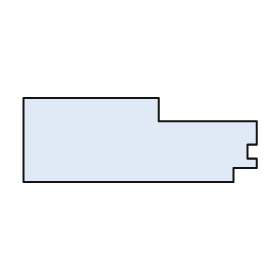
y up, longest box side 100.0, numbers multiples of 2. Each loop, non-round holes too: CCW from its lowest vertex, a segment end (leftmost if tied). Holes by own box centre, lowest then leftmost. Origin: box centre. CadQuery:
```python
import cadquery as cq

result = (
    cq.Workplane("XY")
    .moveTo(-50.0, -18.0)
    .lineTo(40.0, -18.0)
    .lineTo(40.0, -12.0)
    .lineTo(50.0, -12.0)
    .lineTo(50.0, -8.0)
    .lineTo(46.0, -8.0)
    .lineTo(46.0, -2.0)
    .lineTo(50.0, -2.0)
    .lineTo(50.0, 8.0)
    .lineTo(8.0, 8.0)
    .lineTo(8.0, 18.0)
    .lineTo(-50.0, 18.0)
    .close()
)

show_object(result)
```